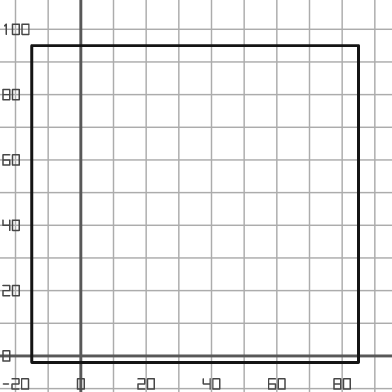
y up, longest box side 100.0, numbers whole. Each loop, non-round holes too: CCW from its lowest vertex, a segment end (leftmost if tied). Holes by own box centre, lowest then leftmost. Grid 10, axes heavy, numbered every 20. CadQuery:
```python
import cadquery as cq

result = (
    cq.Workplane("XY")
    .moveTo(-15.0, -2.0)
    .lineTo(85.0, -2.0)
    .lineTo(85.0, 95.0)
    .lineTo(-15.0, 95.0)
    .close()
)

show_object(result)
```